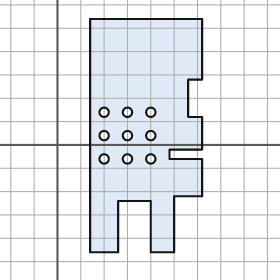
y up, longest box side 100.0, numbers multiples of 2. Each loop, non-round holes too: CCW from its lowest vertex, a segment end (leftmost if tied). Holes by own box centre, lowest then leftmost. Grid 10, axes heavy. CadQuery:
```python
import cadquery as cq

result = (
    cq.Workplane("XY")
    .moveTo(14.0, -46.0)
    .lineTo(26.0, -46.0)
    .lineTo(26.0, -24.0)
    .lineTo(40.0, -24.0)
    .lineTo(40.0, -46.0)
    .lineTo(50.0, -46.0)
    .lineTo(50.0, -22.0)
    .lineTo(62.0, -22.0)
    .lineTo(62.0, -6.0)
    .lineTo(48.0, -6.0)
    .lineTo(48.0, -2.0)
    .lineTo(62.0, -2.0)
    .lineTo(62.0, 12.0)
    .lineTo(56.0, 12.0)
    .lineTo(56.0, 28.0)
    .lineTo(62.0, 28.0)
    .lineTo(62.0, 54.0)
    .lineTo(14.0, 54.0)
    .close()
    .moveTo(20.0, -6.0)
    .circle(2.0)
    .moveTo(30.0, -6.0)
    .circle(2.0)
    .moveTo(40.0, -6.0)
    .circle(2.0)
    .moveTo(20.0, 4.0)
    .circle(2.0)
    .moveTo(30.0, 4.0)
    .circle(2.0)
    .moveTo(40.0, 4.0)
    .circle(2.0)
    .moveTo(20.0, 14.0)
    .circle(2.0)
    .moveTo(30.0, 14.0)
    .circle(2.0)
    .moveTo(40.0, 14.0)
    .circle(2.0)
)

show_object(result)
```